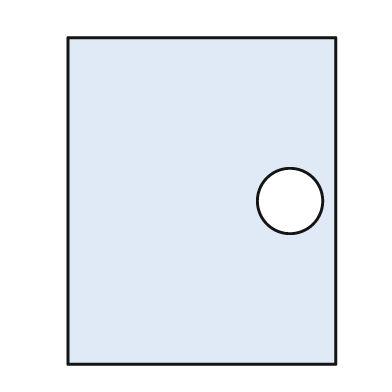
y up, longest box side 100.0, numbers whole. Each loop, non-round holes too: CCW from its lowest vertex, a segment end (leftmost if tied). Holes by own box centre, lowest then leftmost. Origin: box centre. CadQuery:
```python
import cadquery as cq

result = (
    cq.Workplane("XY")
    .moveTo(-41.0, -50.0)
    .lineTo(41.0, -50.0)
    .lineTo(41.0, 50.0)
    .lineTo(-41.0, 50.0)
    .close()
    .moveTo(27.0, 0.0)
    .circle(10.0)
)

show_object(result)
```